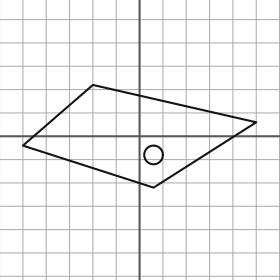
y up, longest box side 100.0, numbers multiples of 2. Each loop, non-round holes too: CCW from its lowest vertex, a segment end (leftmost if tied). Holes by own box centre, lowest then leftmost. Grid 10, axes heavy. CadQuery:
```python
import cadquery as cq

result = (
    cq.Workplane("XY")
    .moveTo(6.0, -22.0)
    .lineTo(50.0, 6.0)
    .lineTo(-20.0, 22.0)
    .lineTo(-50.0, -4.0)
    .close()
    .moveTo(6.0, -8.0)
    .circle(4.0)
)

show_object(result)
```